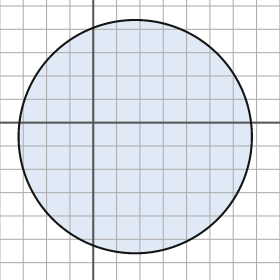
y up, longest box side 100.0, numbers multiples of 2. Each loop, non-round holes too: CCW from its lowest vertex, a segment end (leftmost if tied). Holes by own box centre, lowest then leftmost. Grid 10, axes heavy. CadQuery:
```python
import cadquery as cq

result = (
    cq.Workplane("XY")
    .moveTo(18.0, -6.0)
    .circle(50.0)
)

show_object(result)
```